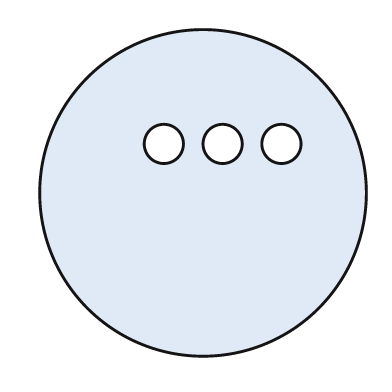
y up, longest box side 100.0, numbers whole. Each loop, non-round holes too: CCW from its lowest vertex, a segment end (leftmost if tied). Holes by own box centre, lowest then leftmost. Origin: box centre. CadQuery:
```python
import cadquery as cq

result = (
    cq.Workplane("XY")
    .moveTo(0.0, 0.0)
    .circle(50.0)
    .moveTo(-12.0, 15.0)
    .circle(6.0)
    .moveTo(6.0, 15.0)
    .circle(6.0)
    .moveTo(24.0, 15.0)
    .circle(6.0)
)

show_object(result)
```